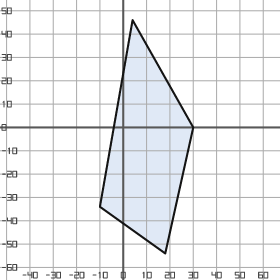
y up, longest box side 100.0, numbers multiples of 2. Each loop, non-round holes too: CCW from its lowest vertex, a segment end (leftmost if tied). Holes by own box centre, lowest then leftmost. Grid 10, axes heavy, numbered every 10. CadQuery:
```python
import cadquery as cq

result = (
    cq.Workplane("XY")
    .moveTo(18.0, -54.0)
    .lineTo(30.0, 0.0)
    .lineTo(4.0, 46.0)
    .lineTo(-10.0, -34.0)
    .close()
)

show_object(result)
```